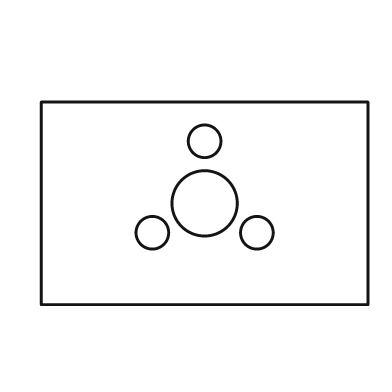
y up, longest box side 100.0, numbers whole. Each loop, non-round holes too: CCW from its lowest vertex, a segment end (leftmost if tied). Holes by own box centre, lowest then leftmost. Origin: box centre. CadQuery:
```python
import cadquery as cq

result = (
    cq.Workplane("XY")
    .moveTo(-50.0, -31.0)
    .lineTo(50.0, -31.0)
    .lineTo(50.0, 31.0)
    .lineTo(-50.0, 31.0)
    .close()
    .moveTo(-16.0, -9.0)
    .circle(5.0)
    .moveTo(16.0, -9.0)
    .circle(5.0)
    .moveTo(0.0, 0.0)
    .circle(10.0)
    .moveTo(0.0, 19.0)
    .circle(5.0)
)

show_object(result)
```